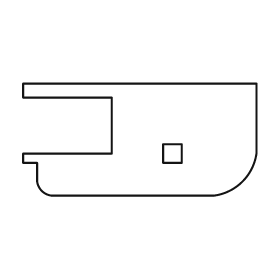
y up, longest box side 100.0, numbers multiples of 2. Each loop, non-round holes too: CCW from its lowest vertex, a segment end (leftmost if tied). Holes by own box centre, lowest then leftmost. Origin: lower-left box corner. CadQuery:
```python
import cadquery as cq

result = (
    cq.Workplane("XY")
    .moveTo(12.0, 0.0)
    .lineTo(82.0, 0.0)
    .threePointArc((94.0, 6.0), (100.0, 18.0))
    .lineTo(100.0, 48.0)
    .lineTo(0.0, 48.0)
    .lineTo(0.0, 42.0)
    .lineTo(38.0, 42.0)
    .lineTo(38.0, 18.0)
    .lineTo(0.0, 18.0)
    .lineTo(0.0, 14.0)
    .lineTo(6.0, 14.0)
    .lineTo(6.0, 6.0)
    .threePointArc((8.0, 2.0), (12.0, 0.0))
    .close()
    .moveTo(60.0, 14.0)
    .lineTo(68.0, 14.0)
    .lineTo(68.0, 22.0)
    .lineTo(60.0, 22.0)
    .close()
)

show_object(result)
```